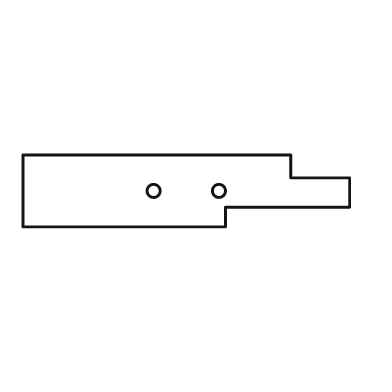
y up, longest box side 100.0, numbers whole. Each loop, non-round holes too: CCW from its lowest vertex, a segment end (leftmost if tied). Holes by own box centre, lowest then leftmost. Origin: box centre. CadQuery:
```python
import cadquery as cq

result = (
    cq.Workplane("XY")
    .moveTo(-50.0, -11.0)
    .lineTo(12.0, -11.0)
    .lineTo(12.0, -5.0)
    .lineTo(50.0, -5.0)
    .lineTo(50.0, 4.0)
    .lineTo(32.0, 4.0)
    .lineTo(32.0, 11.0)
    .lineTo(-50.0, 11.0)
    .close()
    .moveTo(-10.0, 0.0)
    .circle(2.0)
    .moveTo(10.0, 0.0)
    .circle(2.0)
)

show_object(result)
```